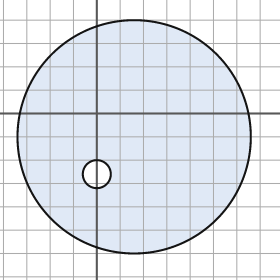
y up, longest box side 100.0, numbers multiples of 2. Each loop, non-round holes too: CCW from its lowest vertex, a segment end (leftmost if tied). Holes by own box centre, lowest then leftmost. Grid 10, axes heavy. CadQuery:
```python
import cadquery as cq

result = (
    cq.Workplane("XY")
    .moveTo(16.0, -10.0)
    .circle(50.0)
    .moveTo(0.0, -26.0)
    .circle(6.0)
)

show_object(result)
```